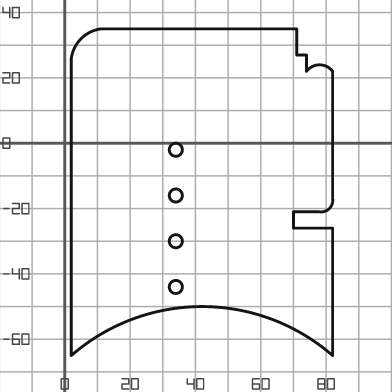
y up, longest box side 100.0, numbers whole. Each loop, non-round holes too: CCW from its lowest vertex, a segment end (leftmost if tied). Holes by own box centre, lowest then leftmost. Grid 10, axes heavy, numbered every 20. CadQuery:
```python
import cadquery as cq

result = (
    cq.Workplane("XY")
    .moveTo(2.0, -65.0)
    .threePointArc((42.0, -50.0), (82.0, -65.0))
    .lineTo(82.0, -26.0)
    .lineTo(70.0, -26.0)
    .lineTo(70.0, -21.0)
    .lineTo(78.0, -21.0)
    .threePointArc((81.0, -20.0), (82.0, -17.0))
    .lineTo(82.0, 22.0)
    .threePointArc((78.0, 24.0), (74.0, 22.0))
    .lineTo(74.0, 27.0)
    .lineTo(71.0, 27.0)
    .lineTo(71.0, 35.0)
    .lineTo(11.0, 35.0)
    .threePointArc((5.0, 32.0), (2.0, 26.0))
    .close()
    .moveTo(34.0, -44.0)
    .circle(2.0)
    .moveTo(34.0, -30.0)
    .circle(2.0)
    .moveTo(34.0, -16.0)
    .circle(2.0)
    .moveTo(34.0, -2.0)
    .circle(2.0)
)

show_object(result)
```